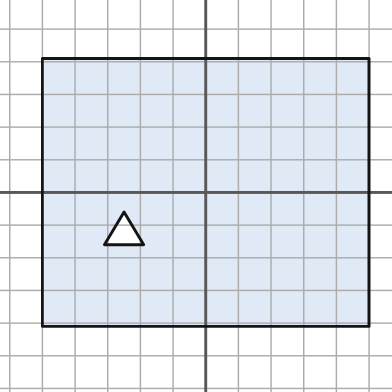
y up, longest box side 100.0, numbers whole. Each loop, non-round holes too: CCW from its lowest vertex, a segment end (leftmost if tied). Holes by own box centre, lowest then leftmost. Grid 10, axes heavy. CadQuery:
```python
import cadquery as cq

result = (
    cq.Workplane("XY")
    .moveTo(-50.0, -41.0)
    .lineTo(50.0, -41.0)
    .lineTo(50.0, 41.0)
    .lineTo(-50.0, 41.0)
    .close()
    .moveTo(-31.0, -16.0)
    .lineTo(-19.0, -16.0)
    .lineTo(-25.0, -6.0)
    .close()
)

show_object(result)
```